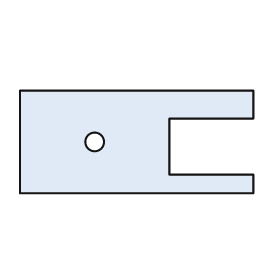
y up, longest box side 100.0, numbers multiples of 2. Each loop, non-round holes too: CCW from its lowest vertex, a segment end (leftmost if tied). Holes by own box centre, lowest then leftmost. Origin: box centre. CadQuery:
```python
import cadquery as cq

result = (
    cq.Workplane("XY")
    .moveTo(-50.0, -22.0)
    .lineTo(50.0, -22.0)
    .lineTo(50.0, -14.0)
    .lineTo(14.0, -14.0)
    .lineTo(14.0, 10.0)
    .lineTo(50.0, 10.0)
    .lineTo(50.0, 22.0)
    .lineTo(-50.0, 22.0)
    .close()
    .moveTo(-18.0, 0.0)
    .circle(4.0)
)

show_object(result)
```